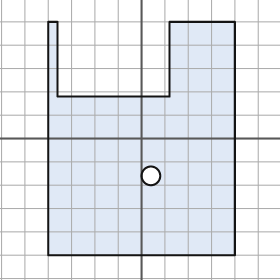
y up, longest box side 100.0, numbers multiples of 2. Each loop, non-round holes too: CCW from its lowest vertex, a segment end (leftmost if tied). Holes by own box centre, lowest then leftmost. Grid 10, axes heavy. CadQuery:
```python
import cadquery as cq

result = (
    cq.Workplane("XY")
    .moveTo(-40.0, -50.0)
    .lineTo(40.0, -50.0)
    .lineTo(40.0, 50.0)
    .lineTo(12.0, 50.0)
    .lineTo(12.0, 18.0)
    .lineTo(-36.0, 18.0)
    .lineTo(-36.0, 50.0)
    .lineTo(-40.0, 50.0)
    .close()
    .moveTo(4.0, -16.0)
    .circle(4.0)
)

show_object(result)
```